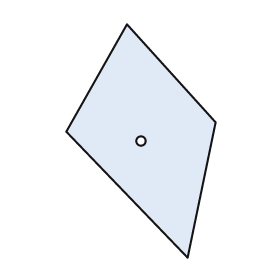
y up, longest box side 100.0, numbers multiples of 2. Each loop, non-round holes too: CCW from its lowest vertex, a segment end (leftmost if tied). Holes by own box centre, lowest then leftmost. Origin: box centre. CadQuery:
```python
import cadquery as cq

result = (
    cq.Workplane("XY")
    .moveTo(20.0, -50.0)
    .lineTo(32.0, 8.0)
    .lineTo(-6.0, 50.0)
    .lineTo(-32.0, 4.0)
    .close()
    .moveTo(0.0, 0.0)
    .circle(2.0)
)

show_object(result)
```